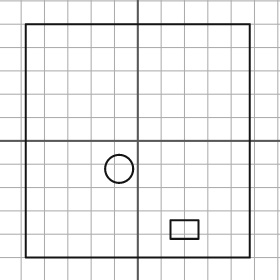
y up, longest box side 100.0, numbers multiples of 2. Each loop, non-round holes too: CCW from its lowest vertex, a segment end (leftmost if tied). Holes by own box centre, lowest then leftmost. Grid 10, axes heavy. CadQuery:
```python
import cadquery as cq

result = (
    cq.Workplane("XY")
    .moveTo(-48.0, -50.0)
    .lineTo(48.0, -50.0)
    .lineTo(48.0, 50.0)
    .lineTo(-48.0, 50.0)
    .close()
    .moveTo(14.0, -42.0)
    .lineTo(26.0, -42.0)
    .lineTo(26.0, -34.0)
    .lineTo(14.0, -34.0)
    .close()
    .moveTo(-8.0, -12.0)
    .circle(6.0)
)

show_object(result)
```